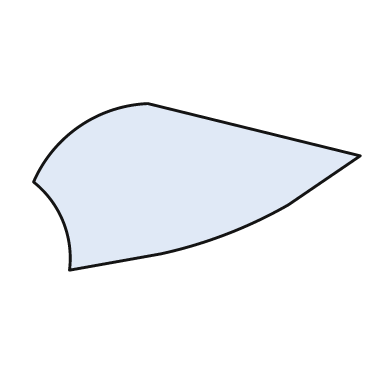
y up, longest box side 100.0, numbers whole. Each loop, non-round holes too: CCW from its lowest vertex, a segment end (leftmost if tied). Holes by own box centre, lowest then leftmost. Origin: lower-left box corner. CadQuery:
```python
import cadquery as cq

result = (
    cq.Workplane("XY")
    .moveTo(11.0, 0.0)
    .lineTo(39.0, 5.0)
    .threePointArc((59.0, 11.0), (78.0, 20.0))
    .lineTo(100.0, 35.0)
    .lineTo(35.0, 51.0)
    .threePointArc((14.0, 44.0), (0.0, 27.0))
    .threePointArc((9.0, 15.0), (11.0, 0.0))
    .close()
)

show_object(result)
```